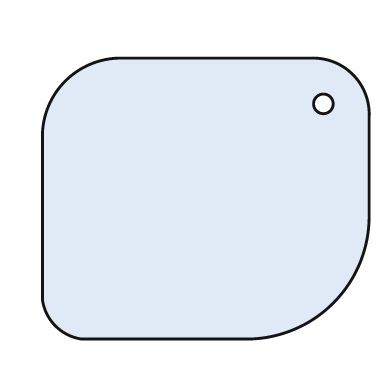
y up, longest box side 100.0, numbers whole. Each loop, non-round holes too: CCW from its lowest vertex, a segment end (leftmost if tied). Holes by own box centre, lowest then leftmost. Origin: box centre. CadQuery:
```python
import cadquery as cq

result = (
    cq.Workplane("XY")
    .moveTo(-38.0, -43.0)
    .lineTo(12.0, -43.0)
    .threePointArc((39.0, -32.0), (50.0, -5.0))
    .lineTo(50.0, 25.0)
    .threePointArc((45.0, 38.0), (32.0, 43.0))
    .lineTo(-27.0, 43.0)
    .threePointArc((-43.0, 36.0), (-50.0, 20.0))
    .lineTo(-50.0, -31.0)
    .threePointArc((-46.0, -39.0), (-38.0, -43.0))
    .close()
    .moveTo(36.0, 29.0)
    .circle(3.0)
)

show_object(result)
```